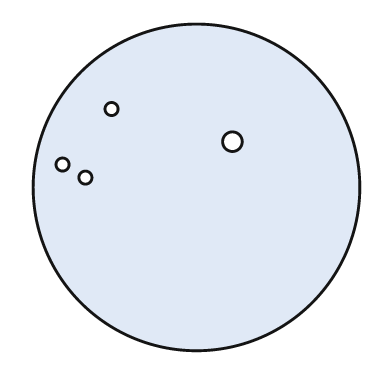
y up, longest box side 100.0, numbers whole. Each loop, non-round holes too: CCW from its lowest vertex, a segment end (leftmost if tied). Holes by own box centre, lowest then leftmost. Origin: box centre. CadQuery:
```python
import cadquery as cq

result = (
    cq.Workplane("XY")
    .moveTo(0.0, 0.0)
    .circle(50.0)
    .moveTo(-34.0, 3.0)
    .circle(2.0)
    .moveTo(-41.0, 7.0)
    .circle(2.0)
    .moveTo(11.0, 14.0)
    .circle(3.0)
    .moveTo(-26.0, 24.0)
    .circle(2.0)
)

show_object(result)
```